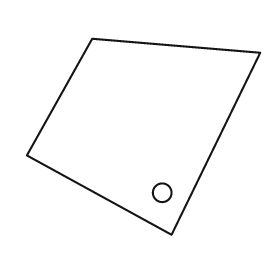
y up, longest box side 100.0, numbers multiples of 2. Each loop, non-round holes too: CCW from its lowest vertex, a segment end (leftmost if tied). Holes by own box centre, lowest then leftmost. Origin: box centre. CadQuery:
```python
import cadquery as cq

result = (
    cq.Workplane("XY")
    .moveTo(12.0, -42.0)
    .lineTo(50.0, 36.0)
    .lineTo(-22.0, 42.0)
    .lineTo(-50.0, -8.0)
    .close()
    .moveTo(8.0, -24.0)
    .circle(4.0)
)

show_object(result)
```